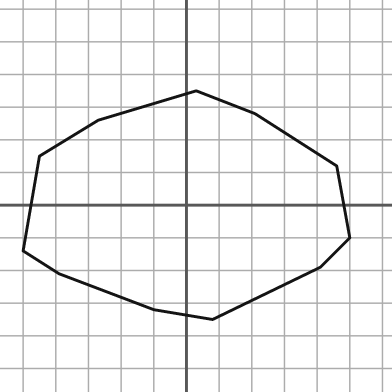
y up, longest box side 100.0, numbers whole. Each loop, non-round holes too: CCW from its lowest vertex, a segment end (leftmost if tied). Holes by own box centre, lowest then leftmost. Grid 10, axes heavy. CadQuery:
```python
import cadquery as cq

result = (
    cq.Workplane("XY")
    .moveTo(8.0, -35.0)
    .lineTo(41.0, -19.0)
    .lineTo(50.0, -10.0)
    .lineTo(46.0, 12.0)
    .lineTo(21.0, 28.0)
    .lineTo(3.0, 35.0)
    .lineTo(-27.0, 26.0)
    .lineTo(-45.0, 15.0)
    .lineTo(-50.0, -14.0)
    .lineTo(-39.0, -21.0)
    .lineTo(-10.0, -32.0)
    .close()
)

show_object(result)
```